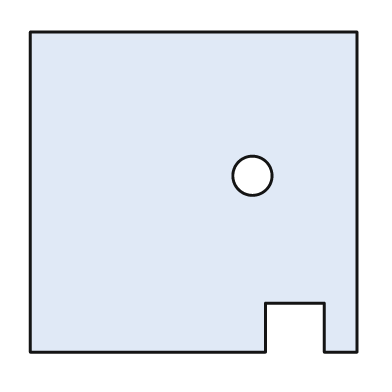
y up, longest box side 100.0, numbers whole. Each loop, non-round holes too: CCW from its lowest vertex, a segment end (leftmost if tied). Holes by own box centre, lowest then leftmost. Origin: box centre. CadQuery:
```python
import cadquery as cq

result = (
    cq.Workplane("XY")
    .moveTo(-50.0, -49.0)
    .lineTo(22.0, -49.0)
    .lineTo(22.0, -34.0)
    .lineTo(40.0, -34.0)
    .lineTo(40.0, -49.0)
    .lineTo(50.0, -49.0)
    .lineTo(50.0, 49.0)
    .lineTo(-50.0, 49.0)
    .close()
    .moveTo(18.0, 5.0)
    .circle(6.0)
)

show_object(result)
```